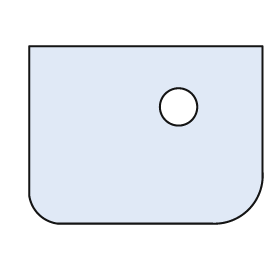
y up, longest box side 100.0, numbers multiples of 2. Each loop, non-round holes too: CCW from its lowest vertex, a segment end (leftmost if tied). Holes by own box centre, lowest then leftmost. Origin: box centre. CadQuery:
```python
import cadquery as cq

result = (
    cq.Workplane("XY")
    .moveTo(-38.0, -38.0)
    .lineTo(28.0, -38.0)
    .threePointArc((44.0, -32.0), (50.0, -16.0))
    .lineTo(50.0, 38.0)
    .lineTo(-50.0, 38.0)
    .lineTo(-50.0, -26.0)
    .threePointArc((-46.0, -34.0), (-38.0, -38.0))
    .close()
    .moveTo(14.0, 12.0)
    .circle(8.0)
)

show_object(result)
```